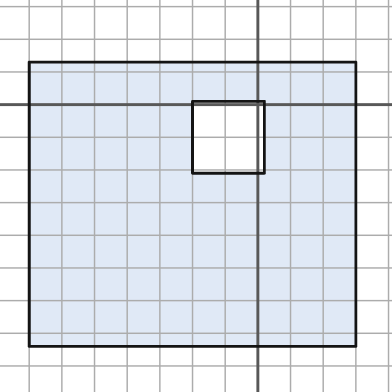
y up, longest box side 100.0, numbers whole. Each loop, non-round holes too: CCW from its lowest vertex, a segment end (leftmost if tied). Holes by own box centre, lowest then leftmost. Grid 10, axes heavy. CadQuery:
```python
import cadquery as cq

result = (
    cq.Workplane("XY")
    .moveTo(-70.0, -74.0)
    .lineTo(30.0, -74.0)
    .lineTo(30.0, 13.0)
    .lineTo(-70.0, 13.0)
    .close()
    .moveTo(-20.0, -21.0)
    .lineTo(2.0, -21.0)
    .lineTo(2.0, 1.0)
    .lineTo(-20.0, 1.0)
    .close()
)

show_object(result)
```